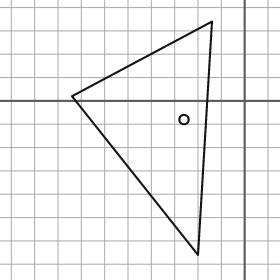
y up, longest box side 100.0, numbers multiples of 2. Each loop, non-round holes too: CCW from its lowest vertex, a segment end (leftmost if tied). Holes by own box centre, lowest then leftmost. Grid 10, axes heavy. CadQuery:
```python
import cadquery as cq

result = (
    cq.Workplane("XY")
    .moveTo(-20.0, -66.0)
    .lineTo(-14.0, 34.0)
    .lineTo(-74.0, 2.0)
    .close()
    .moveTo(-26.0, -8.0)
    .circle(2.0)
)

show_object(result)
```